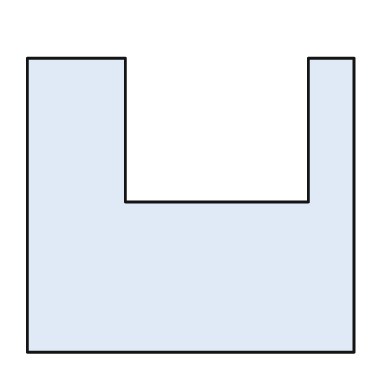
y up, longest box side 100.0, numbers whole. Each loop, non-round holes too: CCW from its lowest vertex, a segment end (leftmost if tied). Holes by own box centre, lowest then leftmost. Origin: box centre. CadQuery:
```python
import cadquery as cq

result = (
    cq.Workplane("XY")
    .moveTo(-50.0, -45.0)
    .lineTo(50.0, -45.0)
    .lineTo(50.0, 45.0)
    .lineTo(36.0, 45.0)
    .lineTo(36.0, 1.0)
    .lineTo(-20.0, 1.0)
    .lineTo(-20.0, 45.0)
    .lineTo(-50.0, 45.0)
    .close()
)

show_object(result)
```